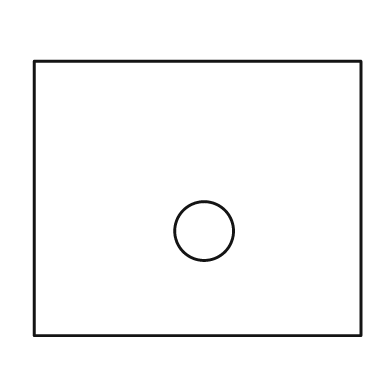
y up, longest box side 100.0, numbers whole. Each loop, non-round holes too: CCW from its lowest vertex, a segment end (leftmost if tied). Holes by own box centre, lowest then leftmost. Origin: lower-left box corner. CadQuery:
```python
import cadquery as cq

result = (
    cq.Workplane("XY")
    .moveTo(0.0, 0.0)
    .lineTo(100.0, 0.0)
    .lineTo(100.0, 84.0)
    .lineTo(0.0, 84.0)
    .close()
    .moveTo(52.0, 32.0)
    .circle(9.0)
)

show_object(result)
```